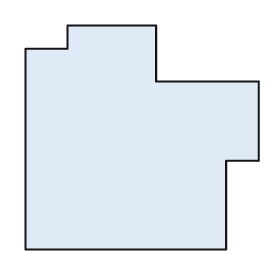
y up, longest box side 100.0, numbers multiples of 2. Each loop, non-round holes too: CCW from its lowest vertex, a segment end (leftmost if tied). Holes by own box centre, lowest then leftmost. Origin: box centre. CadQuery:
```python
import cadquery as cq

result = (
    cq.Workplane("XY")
    .moveTo(-50.0, -48.0)
    .lineTo(36.0, -48.0)
    .lineTo(36.0, -10.0)
    .lineTo(50.0, -10.0)
    .lineTo(50.0, 24.0)
    .lineTo(6.0, 24.0)
    .lineTo(6.0, 48.0)
    .lineTo(-32.0, 48.0)
    .lineTo(-32.0, 38.0)
    .lineTo(-50.0, 38.0)
    .close()
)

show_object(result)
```